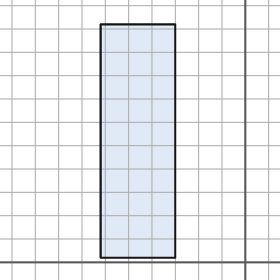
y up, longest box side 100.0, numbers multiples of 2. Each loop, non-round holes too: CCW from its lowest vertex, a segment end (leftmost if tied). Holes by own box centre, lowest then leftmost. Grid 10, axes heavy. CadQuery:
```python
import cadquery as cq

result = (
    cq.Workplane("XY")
    .moveTo(-62.0, 2.0)
    .lineTo(-30.0, 2.0)
    .lineTo(-30.0, 102.0)
    .lineTo(-62.0, 102.0)
    .close()
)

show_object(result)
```